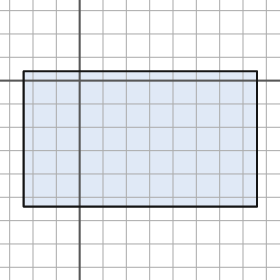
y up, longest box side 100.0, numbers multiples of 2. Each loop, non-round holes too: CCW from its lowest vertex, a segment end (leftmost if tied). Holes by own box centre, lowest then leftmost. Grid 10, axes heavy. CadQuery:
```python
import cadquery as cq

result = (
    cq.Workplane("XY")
    .moveTo(-24.0, -54.0)
    .lineTo(76.0, -54.0)
    .lineTo(76.0, 4.0)
    .lineTo(-24.0, 4.0)
    .close()
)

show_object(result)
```